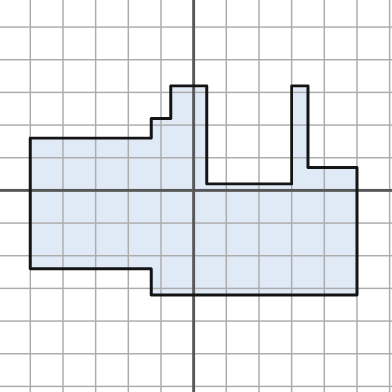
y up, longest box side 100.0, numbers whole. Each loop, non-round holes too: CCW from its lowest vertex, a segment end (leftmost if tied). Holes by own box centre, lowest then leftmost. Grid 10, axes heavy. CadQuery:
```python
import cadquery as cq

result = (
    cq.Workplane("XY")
    .moveTo(-13.0, -32.0)
    .lineTo(50.0, -32.0)
    .lineTo(50.0, 7.0)
    .lineTo(35.0, 7.0)
    .lineTo(35.0, 32.0)
    .lineTo(30.0, 32.0)
    .lineTo(30.0, 2.0)
    .lineTo(4.0, 2.0)
    .lineTo(4.0, 32.0)
    .lineTo(-7.0, 32.0)
    .lineTo(-7.0, 22.0)
    .lineTo(-13.0, 22.0)
    .lineTo(-13.0, 16.0)
    .lineTo(-50.0, 16.0)
    .lineTo(-50.0, -24.0)
    .lineTo(-13.0, -24.0)
    .close()
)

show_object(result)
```